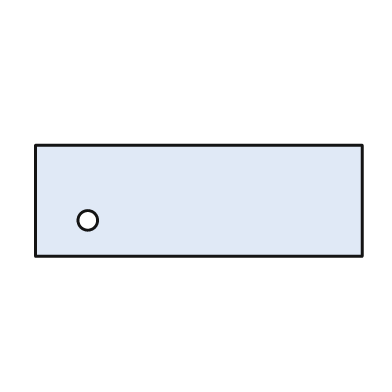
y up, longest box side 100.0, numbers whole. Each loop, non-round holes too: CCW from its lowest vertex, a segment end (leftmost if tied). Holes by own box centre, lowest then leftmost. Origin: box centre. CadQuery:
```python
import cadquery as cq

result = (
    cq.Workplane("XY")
    .moveTo(-50.0, -17.0)
    .lineTo(50.0, -17.0)
    .lineTo(50.0, 17.0)
    .lineTo(-50.0, 17.0)
    .close()
    .moveTo(-34.0, -6.0)
    .circle(3.0)
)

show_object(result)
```